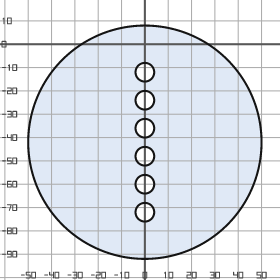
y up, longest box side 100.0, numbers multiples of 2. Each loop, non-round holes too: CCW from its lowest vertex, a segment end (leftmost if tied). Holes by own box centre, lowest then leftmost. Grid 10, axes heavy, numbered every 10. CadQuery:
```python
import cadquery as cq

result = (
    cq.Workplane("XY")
    .moveTo(0.0, -42.0)
    .circle(50.0)
    .moveTo(0.0, -72.0)
    .circle(4.0)
    .moveTo(0.0, -60.0)
    .circle(4.0)
    .moveTo(0.0, -48.0)
    .circle(4.0)
    .moveTo(0.0, -36.0)
    .circle(4.0)
    .moveTo(0.0, -24.0)
    .circle(4.0)
    .moveTo(0.0, -12.0)
    .circle(4.0)
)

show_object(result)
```